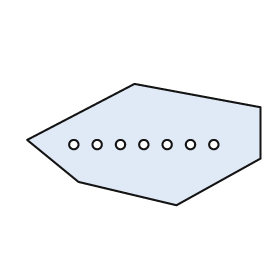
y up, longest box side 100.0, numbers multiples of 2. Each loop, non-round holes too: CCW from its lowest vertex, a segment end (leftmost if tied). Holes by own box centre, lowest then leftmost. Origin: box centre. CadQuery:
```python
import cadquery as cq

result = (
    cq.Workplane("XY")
    .moveTo(14.0, -26.0)
    .lineTo(50.0, -6.0)
    .lineTo(50.0, 16.0)
    .lineTo(-4.0, 26.0)
    .lineTo(-50.0, 2.0)
    .lineTo(-28.0, -16.0)
    .close()
    .moveTo(-30.0, 0.0)
    .circle(2.0)
    .moveTo(-20.0, 0.0)
    .circle(2.0)
    .moveTo(-10.0, 0.0)
    .circle(2.0)
    .moveTo(0.0, 0.0)
    .circle(2.0)
    .moveTo(10.0, 0.0)
    .circle(2.0)
    .moveTo(20.0, 0.0)
    .circle(2.0)
    .moveTo(30.0, 0.0)
    .circle(2.0)
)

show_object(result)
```